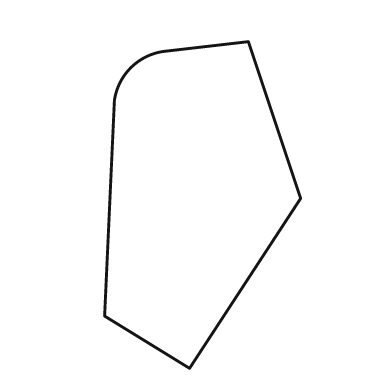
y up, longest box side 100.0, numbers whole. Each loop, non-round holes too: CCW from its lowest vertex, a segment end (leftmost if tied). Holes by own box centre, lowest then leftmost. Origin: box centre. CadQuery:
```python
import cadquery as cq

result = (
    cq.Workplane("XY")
    .moveTo(-4.0, -50.0)
    .lineTo(30.0, 2.0)
    .lineTo(14.0, 50.0)
    .lineTo(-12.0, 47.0)
    .threePointArc((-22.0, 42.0), (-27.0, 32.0))
    .lineTo(-30.0, -34.0)
    .close()
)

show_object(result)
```